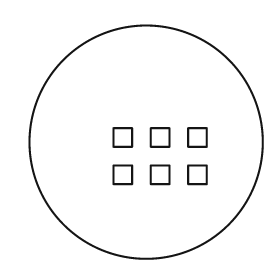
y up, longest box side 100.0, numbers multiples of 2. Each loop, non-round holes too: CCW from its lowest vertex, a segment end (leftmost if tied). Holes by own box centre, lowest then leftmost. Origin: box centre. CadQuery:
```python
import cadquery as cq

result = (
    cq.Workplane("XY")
    .moveTo(0.0, 0.0)
    .circle(50.0)
    .moveTo(-14.0, -18.0)
    .lineTo(-6.0, -18.0)
    .lineTo(-6.0, -10.0)
    .lineTo(-14.0, -10.0)
    .close()
    .moveTo(2.0, -18.0)
    .lineTo(10.0, -18.0)
    .lineTo(10.0, -10.0)
    .lineTo(2.0, -10.0)
    .close()
    .moveTo(18.0, -18.0)
    .lineTo(26.0, -18.0)
    .lineTo(26.0, -10.0)
    .lineTo(18.0, -10.0)
    .close()
    .moveTo(-14.0, -2.0)
    .lineTo(-6.0, -2.0)
    .lineTo(-6.0, 6.0)
    .lineTo(-14.0, 6.0)
    .close()
    .moveTo(2.0, -2.0)
    .lineTo(10.0, -2.0)
    .lineTo(10.0, 6.0)
    .lineTo(2.0, 6.0)
    .close()
    .moveTo(18.0, -2.0)
    .lineTo(26.0, -2.0)
    .lineTo(26.0, 6.0)
    .lineTo(18.0, 6.0)
    .close()
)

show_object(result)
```